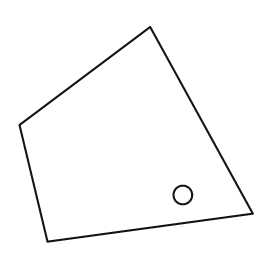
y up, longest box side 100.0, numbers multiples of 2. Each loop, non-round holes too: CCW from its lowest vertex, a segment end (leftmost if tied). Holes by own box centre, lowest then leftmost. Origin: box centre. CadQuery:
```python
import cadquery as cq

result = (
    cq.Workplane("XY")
    .moveTo(-38.0, -46.0)
    .lineTo(50.0, -34.0)
    .lineTo(6.0, 46.0)
    .lineTo(-50.0, 4.0)
    .close()
    .moveTo(20.0, -26.0)
    .circle(4.0)
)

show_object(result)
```